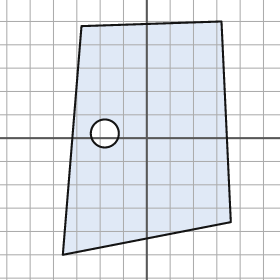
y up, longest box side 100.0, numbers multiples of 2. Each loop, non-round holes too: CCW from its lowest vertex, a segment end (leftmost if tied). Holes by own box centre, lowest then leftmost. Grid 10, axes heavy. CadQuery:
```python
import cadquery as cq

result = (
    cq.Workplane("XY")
    .moveTo(-36.0, -50.0)
    .lineTo(36.0, -36.0)
    .lineTo(32.0, 50.0)
    .lineTo(-28.0, 48.0)
    .close()
    .moveTo(-18.0, 2.0)
    .circle(6.0)
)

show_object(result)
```